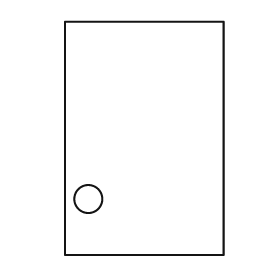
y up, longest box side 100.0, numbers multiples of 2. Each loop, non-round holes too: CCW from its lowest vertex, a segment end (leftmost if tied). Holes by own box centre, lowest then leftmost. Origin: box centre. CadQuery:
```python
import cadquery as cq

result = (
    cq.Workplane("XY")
    .moveTo(-34.0, -50.0)
    .lineTo(34.0, -50.0)
    .lineTo(34.0, 50.0)
    .lineTo(-34.0, 50.0)
    .close()
    .moveTo(-24.0, -26.0)
    .circle(6.0)
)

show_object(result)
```